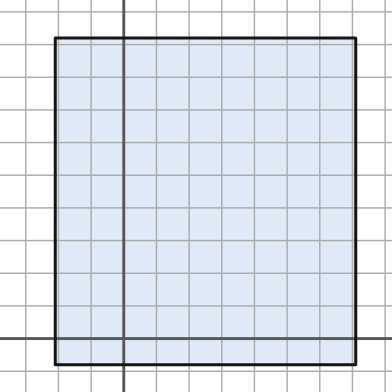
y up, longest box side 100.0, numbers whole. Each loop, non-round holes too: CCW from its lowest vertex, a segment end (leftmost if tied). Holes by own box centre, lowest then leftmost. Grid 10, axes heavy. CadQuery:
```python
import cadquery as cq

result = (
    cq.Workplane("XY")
    .moveTo(-21.0, -8.0)
    .lineTo(71.0, -8.0)
    .lineTo(71.0, 92.0)
    .lineTo(-21.0, 92.0)
    .close()
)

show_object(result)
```